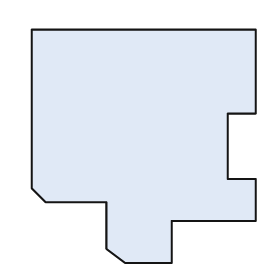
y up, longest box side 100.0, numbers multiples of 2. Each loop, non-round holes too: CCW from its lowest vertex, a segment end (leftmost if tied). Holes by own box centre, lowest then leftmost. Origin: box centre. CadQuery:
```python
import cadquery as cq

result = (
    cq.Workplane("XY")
    .moveTo(-8.0, -50.0)
    .lineTo(12.0, -50.0)
    .lineTo(12.0, -32.0)
    .lineTo(48.0, -32.0)
    .lineTo(48.0, -14.0)
    .lineTo(36.0, -14.0)
    .lineTo(36.0, 14.0)
    .lineTo(48.0, 14.0)
    .lineTo(48.0, 50.0)
    .lineTo(-48.0, 50.0)
    .lineTo(-48.0, -18.0)
    .lineTo(-42.0, -24.0)
    .lineTo(-16.0, -24.0)
    .lineTo(-16.0, -44.0)
    .close()
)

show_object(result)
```